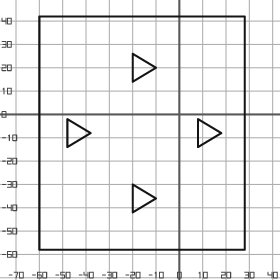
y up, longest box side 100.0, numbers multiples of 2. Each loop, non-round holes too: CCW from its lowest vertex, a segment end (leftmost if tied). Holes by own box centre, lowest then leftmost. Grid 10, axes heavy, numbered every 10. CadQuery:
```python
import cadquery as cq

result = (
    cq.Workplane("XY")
    .moveTo(-60.0, -58.0)
    .lineTo(28.0, -58.0)
    .lineTo(28.0, 42.0)
    .lineTo(-60.0, 42.0)
    .close()
    .moveTo(-20.0, -42.0)
    .lineTo(-10.0, -36.0)
    .lineTo(-20.0, -30.0)
    .close()
    .moveTo(-48.0, -14.0)
    .lineTo(-38.0, -8.0)
    .lineTo(-48.0, -2.0)
    .close()
    .moveTo(8.0, -14.0)
    .lineTo(18.0, -8.0)
    .lineTo(8.0, -2.0)
    .close()
    .moveTo(-20.0, 14.0)
    .lineTo(-10.0, 20.0)
    .lineTo(-20.0, 26.0)
    .close()
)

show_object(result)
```